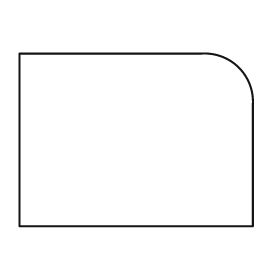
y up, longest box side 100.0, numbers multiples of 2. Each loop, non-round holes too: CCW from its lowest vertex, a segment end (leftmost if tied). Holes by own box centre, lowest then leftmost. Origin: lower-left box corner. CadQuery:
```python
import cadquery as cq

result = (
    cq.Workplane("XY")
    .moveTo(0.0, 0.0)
    .lineTo(100.0, 0.0)
    .lineTo(100.0, 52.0)
    .threePointArc((94.0, 68.0), (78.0, 74.0))
    .lineTo(0.0, 74.0)
    .close()
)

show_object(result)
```